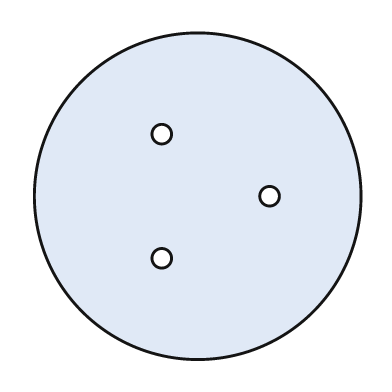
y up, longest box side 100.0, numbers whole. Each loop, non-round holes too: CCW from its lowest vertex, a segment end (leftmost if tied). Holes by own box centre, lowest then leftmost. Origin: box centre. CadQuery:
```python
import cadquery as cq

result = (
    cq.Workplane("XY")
    .moveTo(0.0, 0.0)
    .circle(50.0)
    .moveTo(-11.0, -19.0)
    .circle(3.0)
    .moveTo(22.0, 0.0)
    .circle(3.0)
    .moveTo(-11.0, 19.0)
    .circle(3.0)
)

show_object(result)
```